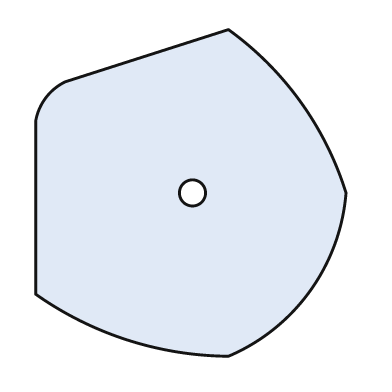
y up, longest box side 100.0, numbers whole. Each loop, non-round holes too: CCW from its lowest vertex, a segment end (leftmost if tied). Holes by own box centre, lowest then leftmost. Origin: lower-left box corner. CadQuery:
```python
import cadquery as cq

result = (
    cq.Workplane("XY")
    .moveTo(59.0, 0.0)
    .threePointArc((84.0, 20.0), (95.0, 50.0))
    .threePointArc((81.0, 78.0), (59.0, 100.0))
    .lineTo(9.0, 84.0)
    .threePointArc((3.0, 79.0), (0.0, 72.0))
    .lineTo(0.0, 19.0)
    .threePointArc((28.0, 5.0), (59.0, 0.0))
    .close()
    .moveTo(48.0, 50.0)
    .circle(4.0)
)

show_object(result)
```